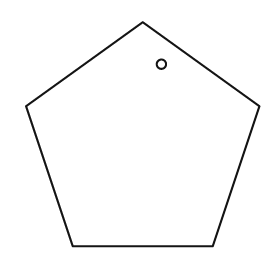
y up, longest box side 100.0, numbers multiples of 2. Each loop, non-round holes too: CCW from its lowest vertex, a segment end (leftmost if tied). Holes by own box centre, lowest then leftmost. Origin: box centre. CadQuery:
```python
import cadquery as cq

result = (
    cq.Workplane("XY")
    .moveTo(-30.0, -48.0)
    .lineTo(30.0, -48.0)
    .lineTo(50.0, 12.0)
    .lineTo(0.0, 48.0)
    .lineTo(-50.0, 12.0)
    .close()
    .moveTo(8.0, 30.0)
    .circle(2.0)
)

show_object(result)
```